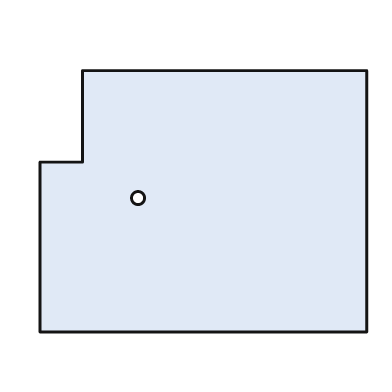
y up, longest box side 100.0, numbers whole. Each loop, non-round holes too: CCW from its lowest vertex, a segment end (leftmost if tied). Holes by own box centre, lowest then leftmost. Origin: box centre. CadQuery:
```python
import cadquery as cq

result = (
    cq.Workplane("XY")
    .moveTo(-50.0, -40.0)
    .lineTo(50.0, -40.0)
    .lineTo(50.0, 40.0)
    .lineTo(-37.0, 40.0)
    .lineTo(-37.0, 12.0)
    .lineTo(-50.0, 12.0)
    .close()
    .moveTo(-20.0, 1.0)
    .circle(2.0)
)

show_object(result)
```